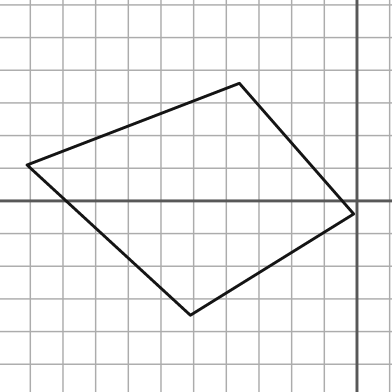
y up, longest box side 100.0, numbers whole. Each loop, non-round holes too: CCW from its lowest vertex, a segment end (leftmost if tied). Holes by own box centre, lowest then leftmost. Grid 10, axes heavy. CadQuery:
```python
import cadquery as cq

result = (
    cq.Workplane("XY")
    .moveTo(-51.0, -35.0)
    .lineTo(-1.0, -4.0)
    .lineTo(-36.0, 36.0)
    .lineTo(-101.0, 11.0)
    .close()
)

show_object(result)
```